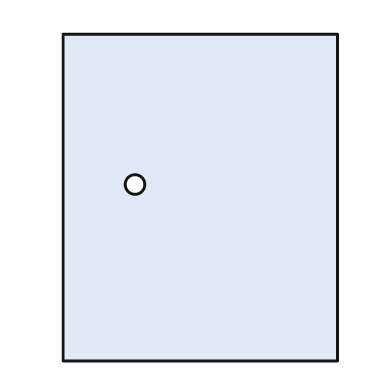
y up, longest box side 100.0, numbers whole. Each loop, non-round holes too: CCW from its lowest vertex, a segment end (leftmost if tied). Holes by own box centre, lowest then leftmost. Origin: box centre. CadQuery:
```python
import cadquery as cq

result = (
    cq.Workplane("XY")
    .moveTo(-42.0, -50.0)
    .lineTo(42.0, -50.0)
    .lineTo(42.0, 50.0)
    .lineTo(-42.0, 50.0)
    .close()
    .moveTo(-20.0, 4.0)
    .circle(3.0)
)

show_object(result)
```